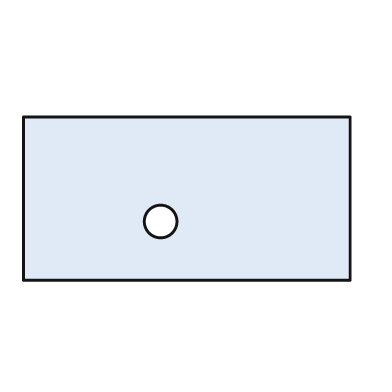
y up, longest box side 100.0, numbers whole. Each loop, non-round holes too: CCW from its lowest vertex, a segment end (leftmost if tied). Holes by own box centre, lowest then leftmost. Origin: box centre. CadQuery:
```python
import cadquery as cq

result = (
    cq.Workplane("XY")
    .moveTo(-50.0, -25.0)
    .lineTo(50.0, -25.0)
    .lineTo(50.0, 25.0)
    .lineTo(-50.0, 25.0)
    .close()
    .moveTo(-8.0, -7.0)
    .circle(5.0)
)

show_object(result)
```